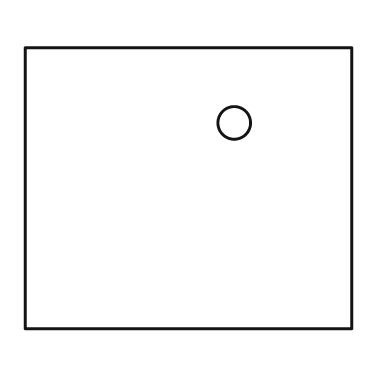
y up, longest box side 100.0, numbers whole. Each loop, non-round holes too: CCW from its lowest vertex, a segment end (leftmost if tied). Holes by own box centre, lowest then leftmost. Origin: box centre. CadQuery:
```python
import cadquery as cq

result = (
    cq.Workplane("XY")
    .moveTo(-50.0, -43.0)
    .lineTo(50.0, -43.0)
    .lineTo(50.0, 43.0)
    .lineTo(-50.0, 43.0)
    .close()
    .moveTo(14.0, 20.0)
    .circle(5.0)
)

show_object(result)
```